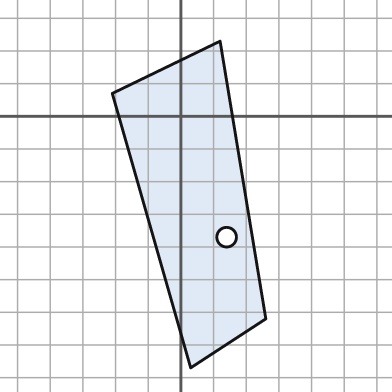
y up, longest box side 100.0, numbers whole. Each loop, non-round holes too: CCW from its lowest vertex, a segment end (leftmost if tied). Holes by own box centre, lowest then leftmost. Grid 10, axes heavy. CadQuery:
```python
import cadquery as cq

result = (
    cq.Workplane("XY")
    .moveTo(3.0, -77.0)
    .lineTo(26.0, -62.0)
    .lineTo(12.0, 23.0)
    .lineTo(-21.0, 7.0)
    .close()
    .moveTo(14.0, -37.0)
    .circle(3.0)
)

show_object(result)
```